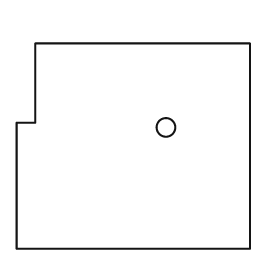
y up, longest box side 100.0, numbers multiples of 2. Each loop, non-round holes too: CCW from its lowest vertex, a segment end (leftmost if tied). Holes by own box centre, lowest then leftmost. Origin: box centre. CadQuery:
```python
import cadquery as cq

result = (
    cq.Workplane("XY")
    .moveTo(-50.0, -44.0)
    .lineTo(50.0, -44.0)
    .lineTo(50.0, 44.0)
    .lineTo(-42.0, 44.0)
    .lineTo(-42.0, 10.0)
    .lineTo(-50.0, 10.0)
    .close()
    .moveTo(14.0, 8.0)
    .circle(4.0)
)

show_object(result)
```